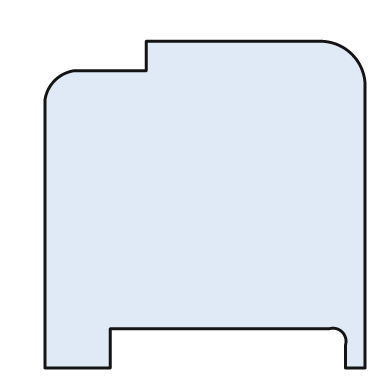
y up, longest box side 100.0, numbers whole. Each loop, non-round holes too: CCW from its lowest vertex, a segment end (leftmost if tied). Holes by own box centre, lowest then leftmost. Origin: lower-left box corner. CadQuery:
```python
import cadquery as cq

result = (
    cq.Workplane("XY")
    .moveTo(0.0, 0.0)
    .lineTo(20.0, 0.0)
    .lineTo(20.0, 12.0)
    .lineTo(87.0, 12.0)
    .threePointArc((91.0, 11.0), (92.0, 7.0))
    .lineTo(92.0, 0.0)
    .lineTo(98.0, 0.0)
    .lineTo(98.0, 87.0)
    .threePointArc((94.0, 96.0), (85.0, 100.0))
    .lineTo(31.0, 100.0)
    .lineTo(31.0, 91.0)
    .lineTo(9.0, 91.0)
    .threePointArc((3.0, 88.0), (0.0, 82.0))
    .close()
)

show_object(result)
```